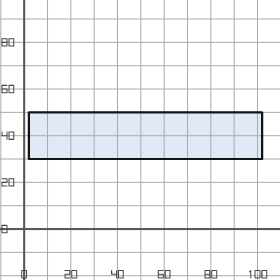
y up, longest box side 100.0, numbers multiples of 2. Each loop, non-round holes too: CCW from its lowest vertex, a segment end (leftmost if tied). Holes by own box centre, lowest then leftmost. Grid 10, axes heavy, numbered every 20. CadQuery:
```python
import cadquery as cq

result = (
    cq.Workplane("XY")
    .moveTo(2.0, 30.0)
    .lineTo(102.0, 30.0)
    .lineTo(102.0, 50.0)
    .lineTo(2.0, 50.0)
    .close()
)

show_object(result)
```